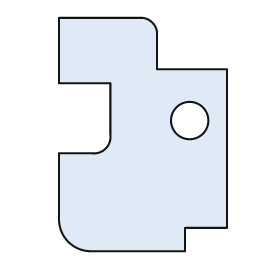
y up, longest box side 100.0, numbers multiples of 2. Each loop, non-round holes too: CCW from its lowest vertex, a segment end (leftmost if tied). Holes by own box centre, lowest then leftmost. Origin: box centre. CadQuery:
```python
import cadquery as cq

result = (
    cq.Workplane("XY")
    .moveTo(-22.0, -50.0)
    .lineTo(18.0, -50.0)
    .lineTo(18.0, -40.0)
    .lineTo(36.0, -40.0)
    .lineTo(36.0, 28.0)
    .lineTo(6.0, 28.0)
    .lineTo(6.0, 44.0)
    .threePointArc((4.0, 48.0), (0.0, 50.0))
    .lineTo(-36.0, 50.0)
    .lineTo(-36.0, 22.0)
    .lineTo(-14.0, 22.0)
    .lineTo(-14.0, 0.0)
    .threePointArc((-16.0, -6.0), (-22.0, -8.0))
    .lineTo(-36.0, -8.0)
    .lineTo(-36.0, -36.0)
    .threePointArc((-32.0, -46.0), (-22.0, -50.0))
    .close()
    .moveTo(20.0, 6.0)
    .circle(8.0)
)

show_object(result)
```